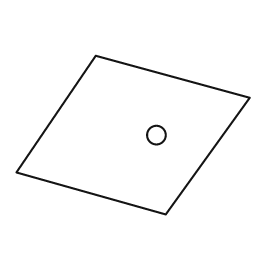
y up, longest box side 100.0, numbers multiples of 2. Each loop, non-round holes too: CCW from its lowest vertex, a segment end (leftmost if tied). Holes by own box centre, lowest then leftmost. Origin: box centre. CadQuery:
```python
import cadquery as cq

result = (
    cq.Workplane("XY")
    .moveTo(14.0, -34.0)
    .lineTo(50.0, 16.0)
    .lineTo(-16.0, 34.0)
    .lineTo(-50.0, -16.0)
    .close()
    .moveTo(10.0, 0.0)
    .circle(4.0)
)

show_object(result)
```